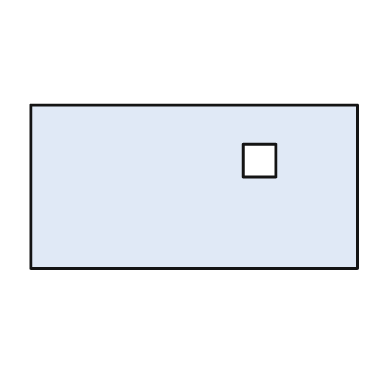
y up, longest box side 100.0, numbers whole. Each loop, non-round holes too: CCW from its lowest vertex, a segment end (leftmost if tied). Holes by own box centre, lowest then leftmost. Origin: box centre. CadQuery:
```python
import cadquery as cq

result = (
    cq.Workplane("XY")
    .moveTo(-50.0, -25.0)
    .lineTo(50.0, -25.0)
    .lineTo(50.0, 25.0)
    .lineTo(-50.0, 25.0)
    .close()
    .moveTo(15.0, 3.0)
    .lineTo(25.0, 3.0)
    .lineTo(25.0, 13.0)
    .lineTo(15.0, 13.0)
    .close()
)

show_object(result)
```